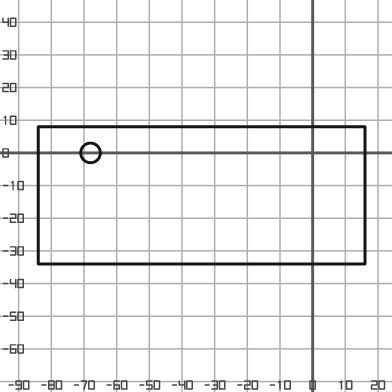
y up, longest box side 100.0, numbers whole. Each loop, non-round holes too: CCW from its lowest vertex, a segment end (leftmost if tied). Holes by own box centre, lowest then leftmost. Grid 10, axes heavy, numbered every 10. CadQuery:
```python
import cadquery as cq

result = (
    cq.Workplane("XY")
    .moveTo(-84.0, -34.0)
    .lineTo(16.0, -34.0)
    .lineTo(16.0, 8.0)
    .lineTo(-84.0, 8.0)
    .close()
    .moveTo(-68.0, 0.0)
    .circle(3.0)
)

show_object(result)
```